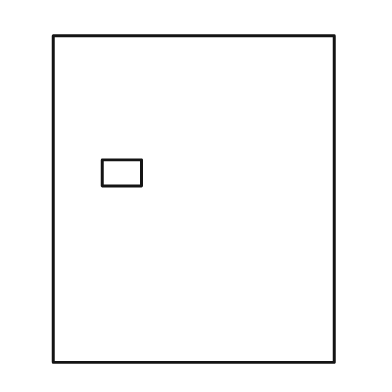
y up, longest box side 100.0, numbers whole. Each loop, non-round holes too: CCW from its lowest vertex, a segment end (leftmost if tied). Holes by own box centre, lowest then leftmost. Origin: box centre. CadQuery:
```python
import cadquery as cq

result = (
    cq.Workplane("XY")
    .moveTo(-43.0, -50.0)
    .lineTo(43.0, -50.0)
    .lineTo(43.0, 50.0)
    .lineTo(-43.0, 50.0)
    .close()
    .moveTo(-28.0, 4.0)
    .lineTo(-16.0, 4.0)
    .lineTo(-16.0, 12.0)
    .lineTo(-28.0, 12.0)
    .close()
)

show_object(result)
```